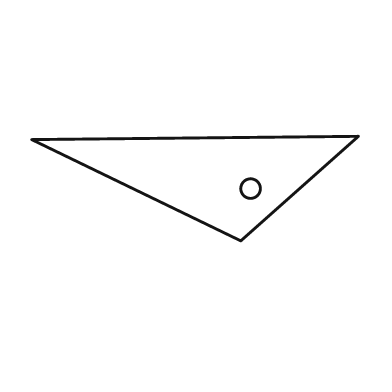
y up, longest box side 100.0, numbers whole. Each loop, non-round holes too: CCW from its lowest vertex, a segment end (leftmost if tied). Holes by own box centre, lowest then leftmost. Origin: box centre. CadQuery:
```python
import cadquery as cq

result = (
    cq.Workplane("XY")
    .moveTo(14.0, -16.0)
    .lineTo(50.0, 16.0)
    .lineTo(-50.0, 15.0)
    .close()
    .moveTo(17.0, 0.0)
    .circle(3.0)
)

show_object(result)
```